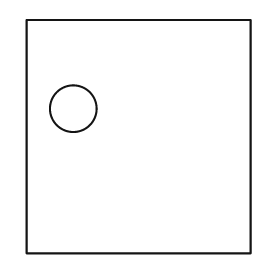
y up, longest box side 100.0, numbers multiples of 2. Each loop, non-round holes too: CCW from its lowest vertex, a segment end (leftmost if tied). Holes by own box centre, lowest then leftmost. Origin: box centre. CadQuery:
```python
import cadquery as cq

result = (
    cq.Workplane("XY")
    .moveTo(-48.0, -50.0)
    .lineTo(48.0, -50.0)
    .lineTo(48.0, 50.0)
    .lineTo(-48.0, 50.0)
    .close()
    .moveTo(-28.0, 12.0)
    .circle(10.0)
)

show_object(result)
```